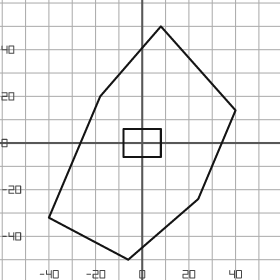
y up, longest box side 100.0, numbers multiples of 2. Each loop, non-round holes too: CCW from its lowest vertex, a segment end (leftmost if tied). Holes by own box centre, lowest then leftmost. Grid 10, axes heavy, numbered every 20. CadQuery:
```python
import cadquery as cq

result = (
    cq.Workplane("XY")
    .moveTo(-6.0, -50.0)
    .lineTo(24.0, -24.0)
    .lineTo(40.0, 14.0)
    .lineTo(8.0, 50.0)
    .lineTo(-18.0, 20.0)
    .lineTo(-40.0, -32.0)
    .close()
    .moveTo(-8.0, -6.0)
    .lineTo(8.0, -6.0)
    .lineTo(8.0, 6.0)
    .lineTo(-8.0, 6.0)
    .close()
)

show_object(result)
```